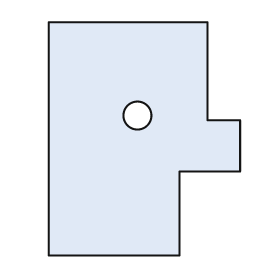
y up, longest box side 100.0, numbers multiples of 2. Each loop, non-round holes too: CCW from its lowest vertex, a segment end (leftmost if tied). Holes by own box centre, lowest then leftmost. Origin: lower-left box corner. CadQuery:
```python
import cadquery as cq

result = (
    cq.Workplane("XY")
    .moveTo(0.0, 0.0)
    .lineTo(56.0, 0.0)
    .lineTo(56.0, 36.0)
    .lineTo(82.0, 36.0)
    .lineTo(82.0, 58.0)
    .lineTo(68.0, 58.0)
    .lineTo(68.0, 100.0)
    .lineTo(0.0, 100.0)
    .close()
    .moveTo(38.0, 60.0)
    .circle(6.0)
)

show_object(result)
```